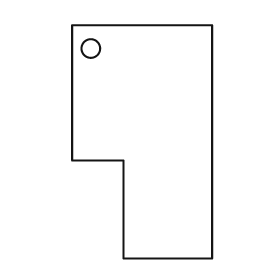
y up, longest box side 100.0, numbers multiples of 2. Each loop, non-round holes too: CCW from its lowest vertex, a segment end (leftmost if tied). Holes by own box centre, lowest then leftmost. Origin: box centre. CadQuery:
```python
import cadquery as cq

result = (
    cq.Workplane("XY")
    .moveTo(-8.0, -50.0)
    .lineTo(30.0, -50.0)
    .lineTo(30.0, 50.0)
    .lineTo(-30.0, 50.0)
    .lineTo(-30.0, -8.0)
    .lineTo(-8.0, -8.0)
    .close()
    .moveTo(-22.0, 40.0)
    .circle(4.0)
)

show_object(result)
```